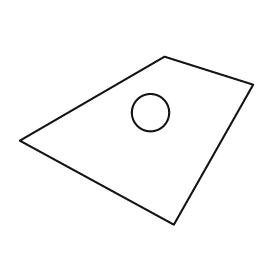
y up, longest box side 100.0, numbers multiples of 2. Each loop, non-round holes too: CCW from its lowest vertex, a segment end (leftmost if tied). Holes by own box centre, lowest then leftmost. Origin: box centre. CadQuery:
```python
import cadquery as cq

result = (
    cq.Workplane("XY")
    .moveTo(16.0, -36.0)
    .lineTo(50.0, 24.0)
    .lineTo(12.0, 36.0)
    .lineTo(-50.0, 0.0)
    .close()
    .moveTo(6.0, 12.0)
    .circle(8.0)
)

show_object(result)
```